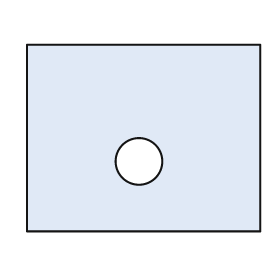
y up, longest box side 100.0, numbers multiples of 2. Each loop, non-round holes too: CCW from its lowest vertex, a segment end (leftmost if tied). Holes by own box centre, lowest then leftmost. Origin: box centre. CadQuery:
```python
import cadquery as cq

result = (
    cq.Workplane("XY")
    .moveTo(-50.0, -40.0)
    .lineTo(50.0, -40.0)
    .lineTo(50.0, 40.0)
    .lineTo(-50.0, 40.0)
    .close()
    .moveTo(-2.0, -10.0)
    .circle(10.0)
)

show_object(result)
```